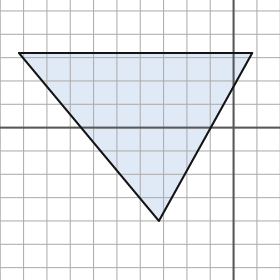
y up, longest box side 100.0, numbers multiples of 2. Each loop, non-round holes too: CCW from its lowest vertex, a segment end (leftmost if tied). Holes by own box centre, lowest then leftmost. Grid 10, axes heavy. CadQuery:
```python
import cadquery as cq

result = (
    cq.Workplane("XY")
    .moveTo(-32.0, -40.0)
    .lineTo(8.0, 32.0)
    .lineTo(-92.0, 32.0)
    .close()
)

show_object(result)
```